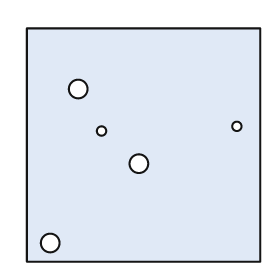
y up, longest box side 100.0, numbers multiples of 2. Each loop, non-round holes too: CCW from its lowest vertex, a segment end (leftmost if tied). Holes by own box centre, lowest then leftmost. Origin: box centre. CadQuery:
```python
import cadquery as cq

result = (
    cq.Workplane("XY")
    .moveTo(-50.0, -50.0)
    .lineTo(50.0, -50.0)
    .lineTo(50.0, 50.0)
    .lineTo(-50.0, 50.0)
    .close()
    .moveTo(-40.0, -42.0)
    .circle(4.0)
    .moveTo(-2.0, -8.0)
    .circle(4.0)
    .moveTo(-18.0, 6.0)
    .circle(2.0)
    .moveTo(40.0, 8.0)
    .circle(2.0)
    .moveTo(-28.0, 24.0)
    .circle(4.0)
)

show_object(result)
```